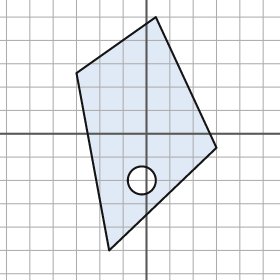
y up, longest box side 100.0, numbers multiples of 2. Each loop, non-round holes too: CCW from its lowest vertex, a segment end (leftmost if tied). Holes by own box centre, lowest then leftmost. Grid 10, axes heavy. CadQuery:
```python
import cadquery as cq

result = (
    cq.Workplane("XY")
    .moveTo(-16.0, -50.0)
    .lineTo(30.0, -6.0)
    .lineTo(4.0, 50.0)
    .lineTo(-30.0, 26.0)
    .close()
    .moveTo(-2.0, -20.0)
    .circle(6.0)
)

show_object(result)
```